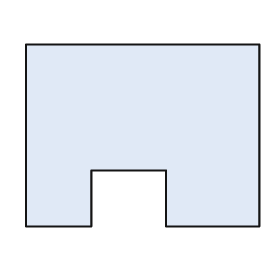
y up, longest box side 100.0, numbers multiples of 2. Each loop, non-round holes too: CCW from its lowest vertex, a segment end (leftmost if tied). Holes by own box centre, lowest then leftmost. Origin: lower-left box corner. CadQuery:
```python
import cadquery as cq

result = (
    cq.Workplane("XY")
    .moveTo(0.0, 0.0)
    .lineTo(28.0, 0.0)
    .lineTo(28.0, 24.0)
    .lineTo(60.0, 24.0)
    .lineTo(60.0, 0.0)
    .lineTo(100.0, 0.0)
    .lineTo(100.0, 78.0)
    .lineTo(0.0, 78.0)
    .close()
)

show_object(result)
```